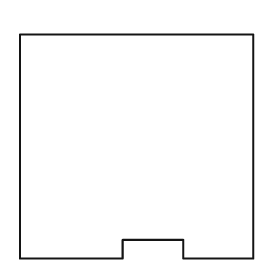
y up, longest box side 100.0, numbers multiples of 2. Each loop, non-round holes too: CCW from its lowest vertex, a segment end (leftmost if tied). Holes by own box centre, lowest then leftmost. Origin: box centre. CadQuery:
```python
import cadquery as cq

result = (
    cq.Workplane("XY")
    .moveTo(-50.0, -48.0)
    .lineTo(-6.0, -48.0)
    .lineTo(-6.0, -40.0)
    .lineTo(20.0, -40.0)
    .lineTo(20.0, -48.0)
    .lineTo(50.0, -48.0)
    .lineTo(50.0, 48.0)
    .lineTo(-50.0, 48.0)
    .close()
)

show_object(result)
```